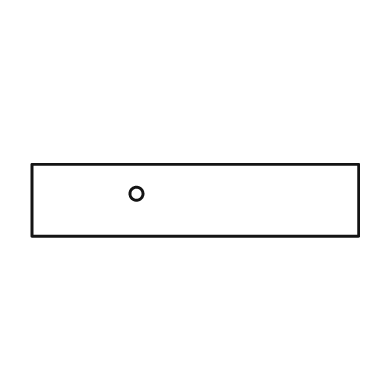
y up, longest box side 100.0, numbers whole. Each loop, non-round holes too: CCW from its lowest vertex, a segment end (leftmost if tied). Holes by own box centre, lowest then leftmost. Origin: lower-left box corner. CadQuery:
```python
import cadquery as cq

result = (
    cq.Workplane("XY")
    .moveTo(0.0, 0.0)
    .lineTo(100.0, 0.0)
    .lineTo(100.0, 22.0)
    .lineTo(0.0, 22.0)
    .close()
    .moveTo(32.0, 13.0)
    .circle(2.0)
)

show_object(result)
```